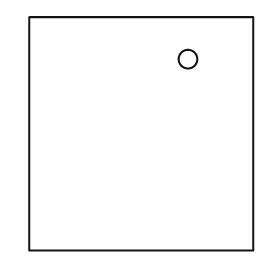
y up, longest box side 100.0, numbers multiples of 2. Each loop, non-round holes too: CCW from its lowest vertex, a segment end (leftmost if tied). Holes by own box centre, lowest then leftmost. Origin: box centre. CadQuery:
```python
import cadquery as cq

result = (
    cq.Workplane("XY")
    .moveTo(-48.0, -50.0)
    .lineTo(48.0, -50.0)
    .lineTo(48.0, 50.0)
    .lineTo(-48.0, 50.0)
    .close()
    .moveTo(20.0, 32.0)
    .circle(4.0)
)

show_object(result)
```